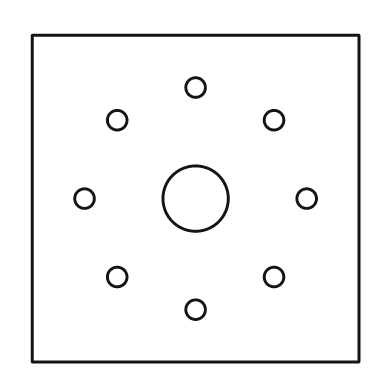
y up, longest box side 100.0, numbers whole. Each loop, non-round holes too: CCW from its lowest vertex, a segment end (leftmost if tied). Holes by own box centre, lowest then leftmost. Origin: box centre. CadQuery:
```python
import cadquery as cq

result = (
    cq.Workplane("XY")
    .moveTo(-50.0, -50.0)
    .lineTo(50.0, -50.0)
    .lineTo(50.0, 50.0)
    .lineTo(-50.0, 50.0)
    .close()
    .moveTo(0.0, -34.0)
    .circle(3.0)
    .moveTo(-24.0, -24.0)
    .circle(3.0)
    .moveTo(24.0, -24.0)
    .circle(3.0)
    .moveTo(-34.0, 0.0)
    .circle(3.0)
    .moveTo(0.0, 0.0)
    .circle(10.0)
    .moveTo(34.0, 0.0)
    .circle(3.0)
    .moveTo(-24.0, 24.0)
    .circle(3.0)
    .moveTo(24.0, 24.0)
    .circle(3.0)
    .moveTo(0.0, 34.0)
    .circle(3.0)
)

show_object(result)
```